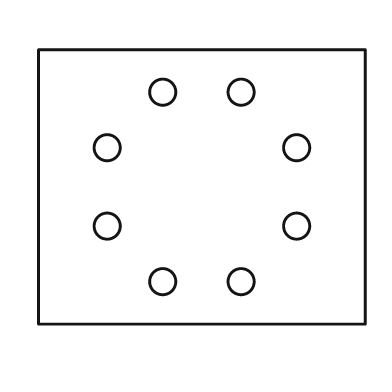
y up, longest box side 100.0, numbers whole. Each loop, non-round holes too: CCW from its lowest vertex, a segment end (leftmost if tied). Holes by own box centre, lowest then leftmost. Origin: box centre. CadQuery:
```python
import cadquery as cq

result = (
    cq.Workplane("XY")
    .moveTo(-50.0, -42.0)
    .lineTo(50.0, -42.0)
    .lineTo(50.0, 42.0)
    .lineTo(-50.0, 42.0)
    .close()
    .moveTo(-12.0, -29.0)
    .circle(4.0)
    .moveTo(12.0, -29.0)
    .circle(4.0)
    .moveTo(-29.0, -12.0)
    .circle(4.0)
    .moveTo(29.0, -12.0)
    .circle(4.0)
    .moveTo(-29.0, 12.0)
    .circle(4.0)
    .moveTo(29.0, 12.0)
    .circle(4.0)
    .moveTo(-12.0, 29.0)
    .circle(4.0)
    .moveTo(12.0, 29.0)
    .circle(4.0)
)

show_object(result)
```